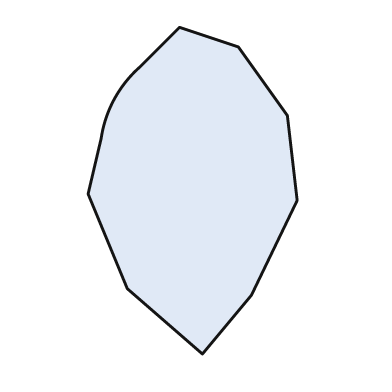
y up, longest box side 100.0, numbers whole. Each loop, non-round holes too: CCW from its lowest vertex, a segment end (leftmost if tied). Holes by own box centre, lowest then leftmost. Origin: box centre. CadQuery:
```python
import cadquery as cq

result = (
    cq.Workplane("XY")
    .moveTo(3.0, -50.0)
    .lineTo(18.0, -32.0)
    .lineTo(32.0, -3.0)
    .lineTo(29.0, 23.0)
    .lineTo(14.0, 44.0)
    .lineTo(-4.0, 50.0)
    .lineTo(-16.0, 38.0)
    .threePointArc((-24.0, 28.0), (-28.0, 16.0))
    .lineTo(-32.0, -1.0)
    .lineTo(-20.0, -30.0)
    .close()
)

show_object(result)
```